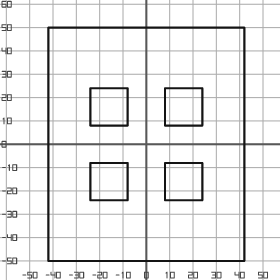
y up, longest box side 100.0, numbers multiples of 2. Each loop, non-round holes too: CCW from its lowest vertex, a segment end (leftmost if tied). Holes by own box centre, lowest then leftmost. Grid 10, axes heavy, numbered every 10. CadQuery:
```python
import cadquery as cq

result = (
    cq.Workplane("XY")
    .moveTo(-42.0, -50.0)
    .lineTo(42.0, -50.0)
    .lineTo(42.0, 50.0)
    .lineTo(-42.0, 50.0)
    .close()
    .moveTo(-24.0, -24.0)
    .lineTo(-8.0, -24.0)
    .lineTo(-8.0, -8.0)
    .lineTo(-24.0, -8.0)
    .close()
    .moveTo(8.0, -24.0)
    .lineTo(24.0, -24.0)
    .lineTo(24.0, -8.0)
    .lineTo(8.0, -8.0)
    .close()
    .moveTo(-24.0, 8.0)
    .lineTo(-8.0, 8.0)
    .lineTo(-8.0, 24.0)
    .lineTo(-24.0, 24.0)
    .close()
    .moveTo(8.0, 8.0)
    .lineTo(24.0, 8.0)
    .lineTo(24.0, 24.0)
    .lineTo(8.0, 24.0)
    .close()
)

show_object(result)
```